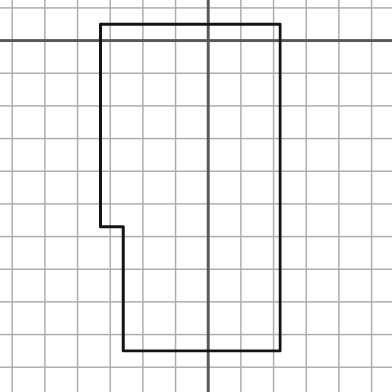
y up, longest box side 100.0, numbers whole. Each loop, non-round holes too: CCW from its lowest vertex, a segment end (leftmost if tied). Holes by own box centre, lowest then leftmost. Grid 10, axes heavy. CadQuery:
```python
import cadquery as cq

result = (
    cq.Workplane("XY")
    .moveTo(-26.0, -95.0)
    .lineTo(22.0, -95.0)
    .lineTo(22.0, 5.0)
    .lineTo(-33.0, 5.0)
    .lineTo(-33.0, -57.0)
    .lineTo(-26.0, -57.0)
    .close()
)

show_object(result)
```